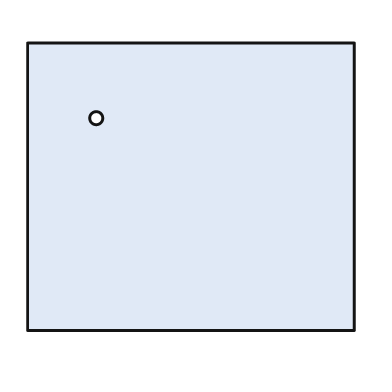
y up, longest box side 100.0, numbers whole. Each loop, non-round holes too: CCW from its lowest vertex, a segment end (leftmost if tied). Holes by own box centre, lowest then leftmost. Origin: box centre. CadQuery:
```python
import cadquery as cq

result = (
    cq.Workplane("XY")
    .moveTo(-50.0, -44.0)
    .lineTo(50.0, -44.0)
    .lineTo(50.0, 44.0)
    .lineTo(-50.0, 44.0)
    .close()
    .moveTo(-29.0, 21.0)
    .circle(2.0)
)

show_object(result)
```